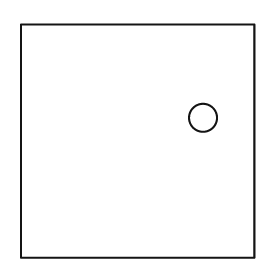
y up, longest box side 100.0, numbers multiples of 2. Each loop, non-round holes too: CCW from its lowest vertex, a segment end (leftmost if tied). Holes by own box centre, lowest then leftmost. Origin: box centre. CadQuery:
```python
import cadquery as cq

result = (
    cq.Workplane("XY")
    .moveTo(-50.0, -50.0)
    .lineTo(50.0, -50.0)
    .lineTo(50.0, 50.0)
    .lineTo(-50.0, 50.0)
    .close()
    .moveTo(28.0, 10.0)
    .circle(6.0)
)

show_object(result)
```